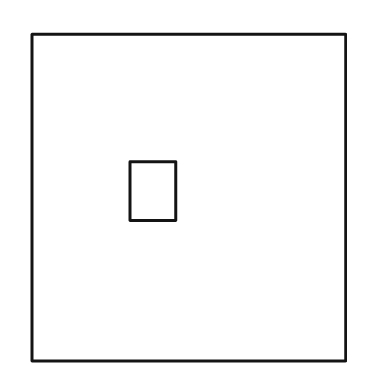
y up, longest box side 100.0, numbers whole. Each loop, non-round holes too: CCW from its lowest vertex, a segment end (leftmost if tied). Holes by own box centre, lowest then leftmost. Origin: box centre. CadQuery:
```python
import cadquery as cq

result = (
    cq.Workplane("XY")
    .moveTo(-48.0, -50.0)
    .lineTo(48.0, -50.0)
    .lineTo(48.0, 50.0)
    .lineTo(-48.0, 50.0)
    .close()
    .moveTo(-18.0, -7.0)
    .lineTo(-4.0, -7.0)
    .lineTo(-4.0, 11.0)
    .lineTo(-18.0, 11.0)
    .close()
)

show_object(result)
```